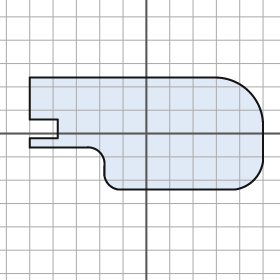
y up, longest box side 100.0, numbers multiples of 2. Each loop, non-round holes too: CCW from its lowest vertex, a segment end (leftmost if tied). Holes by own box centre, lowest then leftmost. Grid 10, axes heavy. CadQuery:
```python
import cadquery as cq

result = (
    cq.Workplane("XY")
    .moveTo(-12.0, -24.0)
    .lineTo(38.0, -24.0)
    .threePointArc((46.0, -20.0), (50.0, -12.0))
    .lineTo(50.0, 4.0)
    .threePointArc((44.0, 18.0), (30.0, 24.0))
    .lineTo(-50.0, 24.0)
    .lineTo(-50.0, 6.0)
    .lineTo(-38.0, 6.0)
    .lineTo(-38.0, -2.0)
    .lineTo(-50.0, -2.0)
    .lineTo(-50.0, -6.0)
    .lineTo(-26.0, -6.0)
    .threePointArc((-20.0, -8.0), (-18.0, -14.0))
    .lineTo(-18.0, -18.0)
    .threePointArc((-16.0, -22.0), (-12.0, -24.0))
    .close()
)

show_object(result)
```